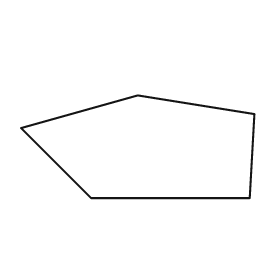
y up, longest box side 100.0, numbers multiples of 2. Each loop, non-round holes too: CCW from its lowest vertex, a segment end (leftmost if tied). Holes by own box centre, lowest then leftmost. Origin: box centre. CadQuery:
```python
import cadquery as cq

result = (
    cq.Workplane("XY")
    .moveTo(-20.0, -22.0)
    .lineTo(48.0, -22.0)
    .lineTo(50.0, 14.0)
    .lineTo(0.0, 22.0)
    .lineTo(-50.0, 8.0)
    .close()
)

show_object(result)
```